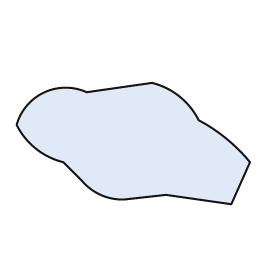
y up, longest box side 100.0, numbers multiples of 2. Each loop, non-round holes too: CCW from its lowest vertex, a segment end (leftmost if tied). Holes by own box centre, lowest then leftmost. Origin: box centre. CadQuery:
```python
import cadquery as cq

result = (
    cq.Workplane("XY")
    .moveTo(42.0, -26.0)
    .lineTo(50.0, -8.0)
    .threePointArc((40.0, 2.0), (28.0, 10.0))
    .threePointArc((20.0, 20.0), (8.0, 26.0))
    .lineTo(-20.0, 22.0)
    .threePointArc((-38.0, 22.0), (-50.0, 8.0))
    .threePointArc((-42.0, -2.0), (-30.0, -8.0))
    .lineTo(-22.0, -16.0)
    .threePointArc((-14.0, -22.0), (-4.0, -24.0))
    .lineTo(14.0, -22.0)
    .close()
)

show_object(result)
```